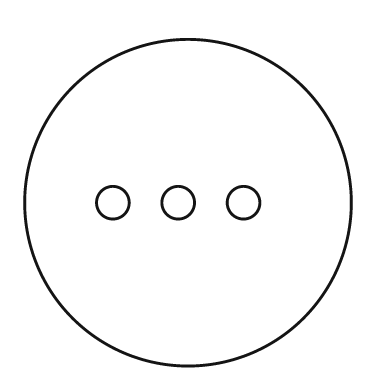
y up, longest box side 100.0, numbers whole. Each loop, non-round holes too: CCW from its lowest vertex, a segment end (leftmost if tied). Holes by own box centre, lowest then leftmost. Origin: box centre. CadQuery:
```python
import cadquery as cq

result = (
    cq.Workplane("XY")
    .moveTo(0.0, 0.0)
    .circle(50.0)
    .moveTo(-23.0, 0.0)
    .circle(5.0)
    .moveTo(-3.0, 0.0)
    .circle(5.0)
    .moveTo(17.0, 0.0)
    .circle(5.0)
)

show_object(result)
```